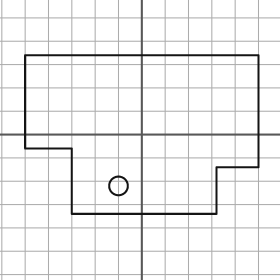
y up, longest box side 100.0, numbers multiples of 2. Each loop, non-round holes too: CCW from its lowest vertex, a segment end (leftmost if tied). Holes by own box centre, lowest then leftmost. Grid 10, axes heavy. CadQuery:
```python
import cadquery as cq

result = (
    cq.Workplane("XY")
    .moveTo(-30.0, -34.0)
    .lineTo(32.0, -34.0)
    .lineTo(32.0, -14.0)
    .lineTo(50.0, -14.0)
    .lineTo(50.0, 34.0)
    .lineTo(-50.0, 34.0)
    .lineTo(-50.0, -6.0)
    .lineTo(-30.0, -6.0)
    .close()
    .moveTo(-10.0, -22.0)
    .circle(4.0)
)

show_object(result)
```